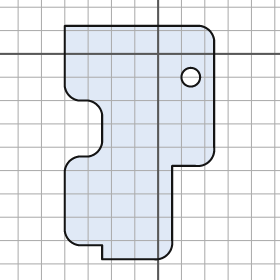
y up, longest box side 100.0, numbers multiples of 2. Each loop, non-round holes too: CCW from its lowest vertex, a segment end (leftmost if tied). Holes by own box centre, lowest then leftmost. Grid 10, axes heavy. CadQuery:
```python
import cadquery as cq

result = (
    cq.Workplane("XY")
    .moveTo(-24.0, -88.0)
    .lineTo(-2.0, -88.0)
    .threePointArc((4.0, -86.0), (6.0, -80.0))
    .lineTo(6.0, -48.0)
    .lineTo(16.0, -48.0)
    .threePointArc((22.0, -46.0), (24.0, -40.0))
    .lineTo(24.0, 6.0)
    .threePointArc((22.0, 10.0), (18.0, 12.0))
    .lineTo(-40.0, 12.0)
    .lineTo(-40.0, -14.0)
    .threePointArc((-38.0, -18.0), (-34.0, -20.0))
    .lineTo(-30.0, -20.0)
    .threePointArc((-26.0, -22.0), (-24.0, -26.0))
    .lineTo(-24.0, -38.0)
    .threePointArc((-26.0, -42.0), (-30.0, -44.0))
    .lineTo(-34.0, -44.0)
    .threePointArc((-38.0, -46.0), (-40.0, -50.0))
    .lineTo(-40.0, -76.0)
    .threePointArc((-38.0, -80.0), (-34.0, -82.0))
    .lineTo(-24.0, -82.0)
    .close()
    .moveTo(14.0, -10.0)
    .circle(4.0)
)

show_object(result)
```